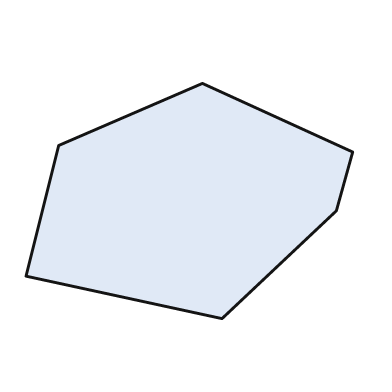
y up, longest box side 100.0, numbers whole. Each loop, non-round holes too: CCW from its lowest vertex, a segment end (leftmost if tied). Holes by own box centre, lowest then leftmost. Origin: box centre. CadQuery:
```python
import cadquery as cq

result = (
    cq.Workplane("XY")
    .moveTo(10.0, -36.0)
    .lineTo(45.0, -3.0)
    .lineTo(50.0, 15.0)
    .lineTo(4.0, 36.0)
    .lineTo(-40.0, 17.0)
    .lineTo(-50.0, -23.0)
    .close()
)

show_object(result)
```